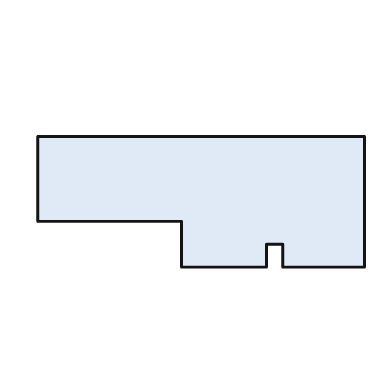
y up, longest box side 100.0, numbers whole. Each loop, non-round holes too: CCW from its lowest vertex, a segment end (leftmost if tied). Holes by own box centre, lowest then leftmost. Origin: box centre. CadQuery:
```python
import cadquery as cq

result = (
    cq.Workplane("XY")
    .moveTo(-6.0, -20.0)
    .lineTo(20.0, -20.0)
    .lineTo(20.0, -13.0)
    .lineTo(25.0, -13.0)
    .lineTo(25.0, -20.0)
    .lineTo(50.0, -20.0)
    .lineTo(50.0, 20.0)
    .lineTo(-50.0, 20.0)
    .lineTo(-50.0, -6.0)
    .lineTo(-6.0, -6.0)
    .close()
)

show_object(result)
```